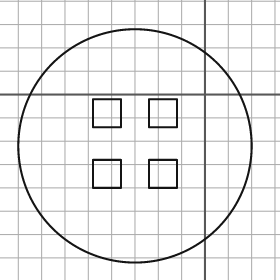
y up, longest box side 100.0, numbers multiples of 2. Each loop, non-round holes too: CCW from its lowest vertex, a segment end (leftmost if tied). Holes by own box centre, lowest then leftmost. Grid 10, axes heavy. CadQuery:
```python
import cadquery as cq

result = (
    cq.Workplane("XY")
    .moveTo(-30.0, -22.0)
    .circle(50.0)
    .moveTo(-48.0, -40.0)
    .lineTo(-36.0, -40.0)
    .lineTo(-36.0, -28.0)
    .lineTo(-48.0, -28.0)
    .close()
    .moveTo(-24.0, -40.0)
    .lineTo(-12.0, -40.0)
    .lineTo(-12.0, -28.0)
    .lineTo(-24.0, -28.0)
    .close()
    .moveTo(-48.0, -14.0)
    .lineTo(-36.0, -14.0)
    .lineTo(-36.0, -2.0)
    .lineTo(-48.0, -2.0)
    .close()
    .moveTo(-24.0, -14.0)
    .lineTo(-12.0, -14.0)
    .lineTo(-12.0, -2.0)
    .lineTo(-24.0, -2.0)
    .close()
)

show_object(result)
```